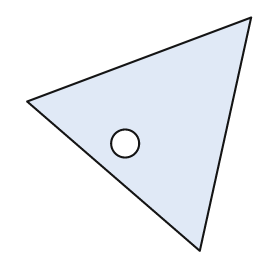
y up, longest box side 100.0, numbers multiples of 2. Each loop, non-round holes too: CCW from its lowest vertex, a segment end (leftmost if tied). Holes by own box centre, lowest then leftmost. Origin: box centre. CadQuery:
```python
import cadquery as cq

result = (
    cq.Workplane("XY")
    .moveTo(26.0, -50.0)
    .lineTo(48.0, 50.0)
    .lineTo(-48.0, 14.0)
    .close()
    .moveTo(-6.0, -4.0)
    .circle(6.0)
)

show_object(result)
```